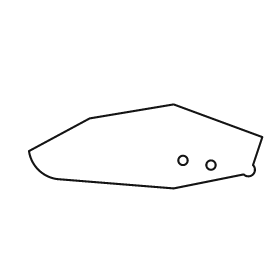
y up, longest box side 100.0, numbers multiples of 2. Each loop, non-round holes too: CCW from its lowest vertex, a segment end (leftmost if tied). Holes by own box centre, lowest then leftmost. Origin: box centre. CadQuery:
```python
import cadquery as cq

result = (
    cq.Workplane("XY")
    .moveTo(12.0, -18.0)
    .lineTo(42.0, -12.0)
    .threePointArc((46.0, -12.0), (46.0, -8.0))
    .lineTo(50.0, 4.0)
    .lineTo(12.0, 18.0)
    .lineTo(-24.0, 12.0)
    .lineTo(-50.0, -2.0)
    .threePointArc((-46.0, -10.0), (-38.0, -14.0))
    .close()
    .moveTo(28.0, -8.0)
    .circle(2.0)
    .moveTo(16.0, -6.0)
    .circle(2.0)
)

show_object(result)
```